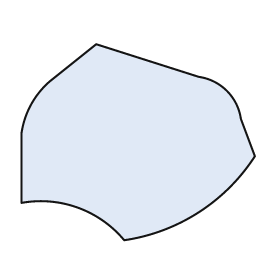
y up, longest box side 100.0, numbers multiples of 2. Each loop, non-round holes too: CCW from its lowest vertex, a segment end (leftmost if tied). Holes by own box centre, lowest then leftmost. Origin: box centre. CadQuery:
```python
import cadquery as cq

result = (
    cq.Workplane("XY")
    .moveTo(-6.0, -42.0)
    .threePointArc((26.0, -30.0), (50.0, -6.0))
    .lineTo(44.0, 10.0)
    .threePointArc((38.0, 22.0), (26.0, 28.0))
    .lineTo(-18.0, 42.0)
    .lineTo(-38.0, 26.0)
    .threePointArc((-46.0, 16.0), (-50.0, 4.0))
    .lineTo(-50.0, -26.0)
    .threePointArc((-26.0, -28.0), (-6.0, -42.0))
    .close()
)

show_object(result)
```